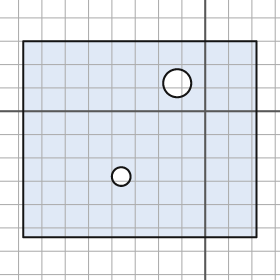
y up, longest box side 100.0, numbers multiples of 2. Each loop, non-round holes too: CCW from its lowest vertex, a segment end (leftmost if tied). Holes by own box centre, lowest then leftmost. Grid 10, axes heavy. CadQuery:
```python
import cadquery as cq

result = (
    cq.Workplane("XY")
    .moveTo(-78.0, -54.0)
    .lineTo(22.0, -54.0)
    .lineTo(22.0, 30.0)
    .lineTo(-78.0, 30.0)
    .close()
    .moveTo(-36.0, -28.0)
    .circle(4.0)
    .moveTo(-12.0, 12.0)
    .circle(6.0)
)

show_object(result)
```